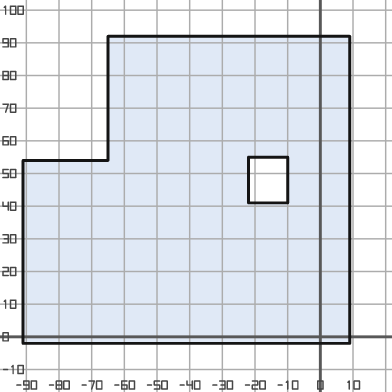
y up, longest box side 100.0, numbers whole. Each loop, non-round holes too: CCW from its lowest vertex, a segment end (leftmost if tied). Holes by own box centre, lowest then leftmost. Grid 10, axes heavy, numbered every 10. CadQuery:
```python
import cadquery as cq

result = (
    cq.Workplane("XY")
    .moveTo(-91.0, -2.0)
    .lineTo(9.0, -2.0)
    .lineTo(9.0, 92.0)
    .lineTo(-65.0, 92.0)
    .lineTo(-65.0, 54.0)
    .lineTo(-91.0, 54.0)
    .close()
    .moveTo(-22.0, 41.0)
    .lineTo(-10.0, 41.0)
    .lineTo(-10.0, 55.0)
    .lineTo(-22.0, 55.0)
    .close()
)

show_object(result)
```